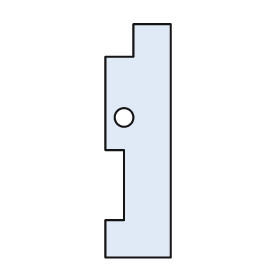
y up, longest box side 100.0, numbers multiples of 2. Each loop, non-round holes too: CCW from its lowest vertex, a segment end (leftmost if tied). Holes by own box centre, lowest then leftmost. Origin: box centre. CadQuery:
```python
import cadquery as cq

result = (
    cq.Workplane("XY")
    .moveTo(-14.0, -50.0)
    .lineTo(14.0, -50.0)
    .lineTo(14.0, 50.0)
    .lineTo(-2.0, 50.0)
    .lineTo(-2.0, 36.0)
    .lineTo(-14.0, 36.0)
    .lineTo(-14.0, -4.0)
    .lineTo(-6.0, -4.0)
    .lineTo(-6.0, -34.0)
    .lineTo(-14.0, -34.0)
    .close()
    .moveTo(-6.0, 10.0)
    .circle(4.0)
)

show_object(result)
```